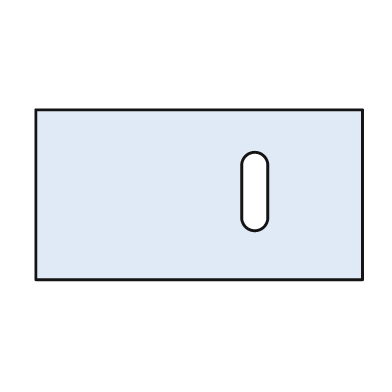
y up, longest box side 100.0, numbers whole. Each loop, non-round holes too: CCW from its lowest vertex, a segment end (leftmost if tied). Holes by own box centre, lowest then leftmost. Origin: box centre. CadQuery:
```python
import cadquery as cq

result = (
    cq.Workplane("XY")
    .moveTo(-50.0, -26.0)
    .lineTo(50.0, -26.0)
    .lineTo(50.0, 26.0)
    .lineTo(-50.0, 26.0)
    .close()
    .moveTo(13.0, -7.0)
    .threePointArc((17.0, -11.0), (21.0, -7.0))
    .lineTo(21.0, 9.0)
    .threePointArc((17.0, 13.0), (13.0, 9.0))
    .close()
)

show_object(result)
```